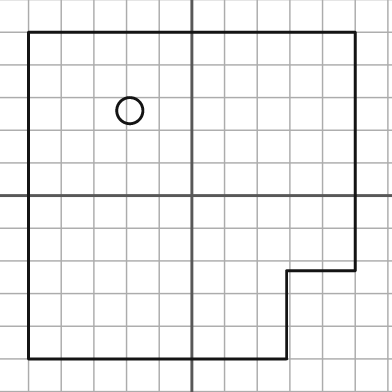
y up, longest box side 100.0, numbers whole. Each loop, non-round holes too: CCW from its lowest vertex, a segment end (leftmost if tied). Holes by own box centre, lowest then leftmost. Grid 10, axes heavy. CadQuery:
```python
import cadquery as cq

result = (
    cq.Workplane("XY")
    .moveTo(-50.0, -50.0)
    .lineTo(29.0, -50.0)
    .lineTo(29.0, -23.0)
    .lineTo(50.0, -23.0)
    .lineTo(50.0, 50.0)
    .lineTo(-50.0, 50.0)
    .close()
    .moveTo(-19.0, 26.0)
    .circle(4.0)
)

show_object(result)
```